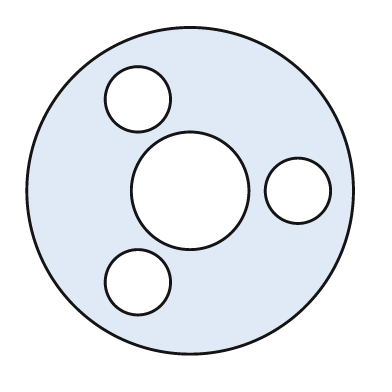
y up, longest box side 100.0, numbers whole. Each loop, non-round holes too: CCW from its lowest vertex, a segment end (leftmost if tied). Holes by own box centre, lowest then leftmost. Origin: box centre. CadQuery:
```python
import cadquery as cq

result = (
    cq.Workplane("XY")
    .moveTo(0.0, 0.0)
    .circle(50.0)
    .moveTo(-16.0, -28.0)
    .circle(10.0)
    .moveTo(0.0, 0.0)
    .circle(18.0)
    .moveTo(33.0, 0.0)
    .circle(10.0)
    .moveTo(-16.0, 28.0)
    .circle(10.0)
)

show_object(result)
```